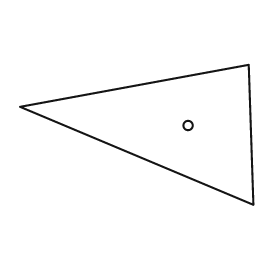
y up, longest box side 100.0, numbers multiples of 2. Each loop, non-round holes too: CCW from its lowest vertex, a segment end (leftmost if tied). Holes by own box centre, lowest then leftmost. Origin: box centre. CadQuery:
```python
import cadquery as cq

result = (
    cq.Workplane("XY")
    .moveTo(50.0, -30.0)
    .lineTo(48.0, 30.0)
    .lineTo(-50.0, 12.0)
    .close()
    .moveTo(22.0, 4.0)
    .circle(2.0)
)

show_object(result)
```